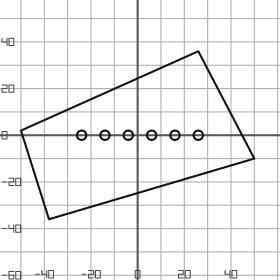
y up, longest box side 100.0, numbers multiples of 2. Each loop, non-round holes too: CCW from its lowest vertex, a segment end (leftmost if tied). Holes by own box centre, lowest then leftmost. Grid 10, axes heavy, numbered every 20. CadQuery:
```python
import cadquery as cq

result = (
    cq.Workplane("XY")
    .moveTo(-38.0, -36.0)
    .lineTo(50.0, -10.0)
    .lineTo(26.0, 36.0)
    .lineTo(-50.0, 2.0)
    .close()
    .moveTo(-24.0, 0.0)
    .circle(2.0)
    .moveTo(-14.0, 0.0)
    .circle(2.0)
    .moveTo(-4.0, 0.0)
    .circle(2.0)
    .moveTo(6.0, 0.0)
    .circle(2.0)
    .moveTo(16.0, 0.0)
    .circle(2.0)
    .moveTo(26.0, 0.0)
    .circle(2.0)
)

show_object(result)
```